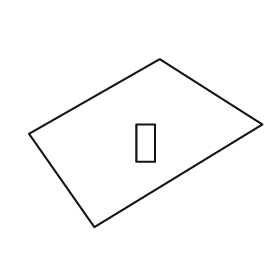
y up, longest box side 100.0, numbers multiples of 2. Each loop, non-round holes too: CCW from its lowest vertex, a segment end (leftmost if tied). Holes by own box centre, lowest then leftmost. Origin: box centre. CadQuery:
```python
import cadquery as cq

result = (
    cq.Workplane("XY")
    .moveTo(-22.0, -36.0)
    .lineTo(50.0, 8.0)
    .lineTo(6.0, 36.0)
    .lineTo(-50.0, 4.0)
    .close()
    .moveTo(-4.0, -8.0)
    .lineTo(4.0, -8.0)
    .lineTo(4.0, 8.0)
    .lineTo(-4.0, 8.0)
    .close()
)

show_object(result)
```